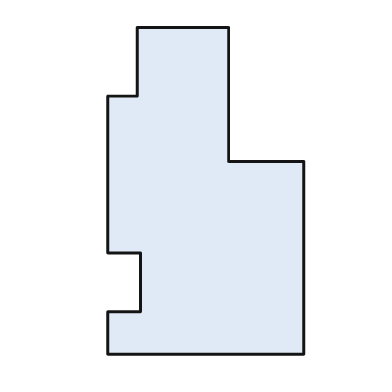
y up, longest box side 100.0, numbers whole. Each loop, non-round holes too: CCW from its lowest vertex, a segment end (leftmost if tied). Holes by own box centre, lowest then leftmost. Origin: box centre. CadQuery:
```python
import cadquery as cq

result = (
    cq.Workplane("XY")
    .moveTo(-30.0, -50.0)
    .lineTo(30.0, -50.0)
    .lineTo(30.0, 9.0)
    .lineTo(7.0, 9.0)
    .lineTo(7.0, 50.0)
    .lineTo(-21.0, 50.0)
    .lineTo(-21.0, 29.0)
    .lineTo(-30.0, 29.0)
    .lineTo(-30.0, -19.0)
    .lineTo(-20.0, -19.0)
    .lineTo(-20.0, -37.0)
    .lineTo(-30.0, -37.0)
    .close()
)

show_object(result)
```